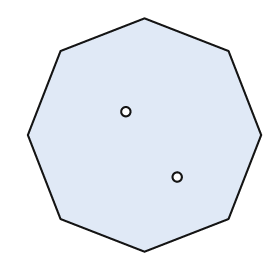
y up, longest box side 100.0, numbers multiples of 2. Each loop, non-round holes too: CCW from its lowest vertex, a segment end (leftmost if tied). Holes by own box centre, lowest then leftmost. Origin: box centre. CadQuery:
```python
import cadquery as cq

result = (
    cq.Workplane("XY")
    .moveTo(0.0, -50.0)
    .lineTo(36.0, -36.0)
    .lineTo(50.0, 0.0)
    .lineTo(36.0, 36.0)
    .lineTo(0.0, 50.0)
    .lineTo(-36.0, 36.0)
    .lineTo(-50.0, 0.0)
    .lineTo(-36.0, -36.0)
    .close()
    .moveTo(14.0, -18.0)
    .circle(2.0)
    .moveTo(-8.0, 10.0)
    .circle(2.0)
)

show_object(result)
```